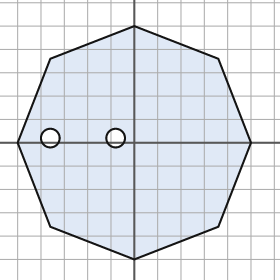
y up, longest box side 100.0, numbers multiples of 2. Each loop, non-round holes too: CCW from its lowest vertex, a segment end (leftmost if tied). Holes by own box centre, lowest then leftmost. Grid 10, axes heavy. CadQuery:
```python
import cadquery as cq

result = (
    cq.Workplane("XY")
    .moveTo(0.0, -50.0)
    .lineTo(36.0, -36.0)
    .lineTo(50.0, 0.0)
    .lineTo(36.0, 36.0)
    .lineTo(0.0, 50.0)
    .lineTo(-36.0, 36.0)
    .lineTo(-50.0, 0.0)
    .lineTo(-36.0, -36.0)
    .close()
    .moveTo(-36.0, 2.0)
    .circle(4.0)
    .moveTo(-8.0, 2.0)
    .circle(4.0)
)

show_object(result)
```